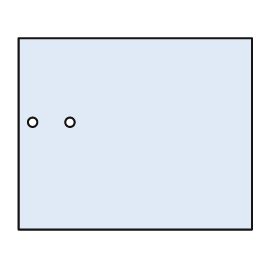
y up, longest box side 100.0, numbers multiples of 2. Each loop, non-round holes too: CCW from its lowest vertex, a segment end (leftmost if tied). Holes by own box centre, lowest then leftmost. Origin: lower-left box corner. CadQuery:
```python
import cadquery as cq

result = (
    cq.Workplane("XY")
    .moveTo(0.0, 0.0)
    .lineTo(100.0, 0.0)
    .lineTo(100.0, 82.0)
    .lineTo(0.0, 82.0)
    .close()
    .moveTo(6.0, 46.0)
    .circle(2.0)
    .moveTo(22.0, 46.0)
    .circle(2.0)
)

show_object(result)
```